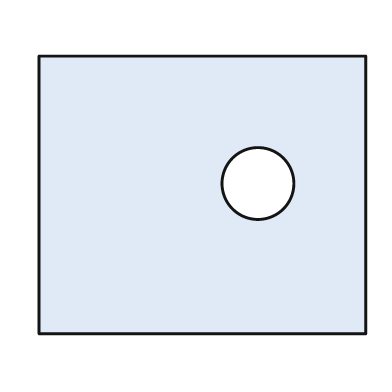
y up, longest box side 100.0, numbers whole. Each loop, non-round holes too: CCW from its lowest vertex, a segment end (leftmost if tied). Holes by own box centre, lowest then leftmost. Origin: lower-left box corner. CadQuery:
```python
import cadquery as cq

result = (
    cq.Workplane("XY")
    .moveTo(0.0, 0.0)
    .lineTo(100.0, 0.0)
    .lineTo(100.0, 85.0)
    .lineTo(0.0, 85.0)
    .close()
    .moveTo(67.0, 46.0)
    .circle(11.0)
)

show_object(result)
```